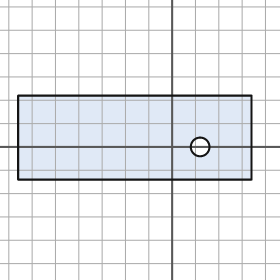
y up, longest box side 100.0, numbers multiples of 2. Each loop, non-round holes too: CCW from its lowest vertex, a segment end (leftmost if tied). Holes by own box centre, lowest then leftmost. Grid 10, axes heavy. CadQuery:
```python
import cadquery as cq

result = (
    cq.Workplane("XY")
    .moveTo(-66.0, -14.0)
    .lineTo(34.0, -14.0)
    .lineTo(34.0, 22.0)
    .lineTo(-66.0, 22.0)
    .close()
    .moveTo(12.0, 0.0)
    .circle(4.0)
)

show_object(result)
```